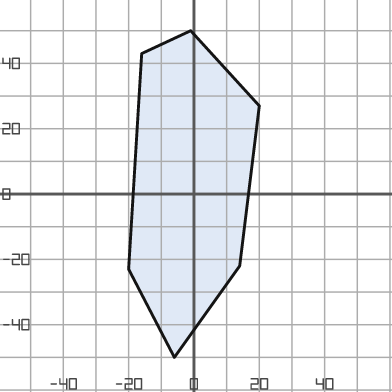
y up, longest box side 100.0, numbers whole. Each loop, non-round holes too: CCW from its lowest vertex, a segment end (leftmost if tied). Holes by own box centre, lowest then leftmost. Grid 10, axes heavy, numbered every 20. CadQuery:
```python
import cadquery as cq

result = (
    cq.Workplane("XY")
    .moveTo(-6.0, -50.0)
    .lineTo(14.0, -22.0)
    .lineTo(20.0, 27.0)
    .lineTo(-1.0, 50.0)
    .lineTo(-16.0, 43.0)
    .lineTo(-20.0, -23.0)
    .close()
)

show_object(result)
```